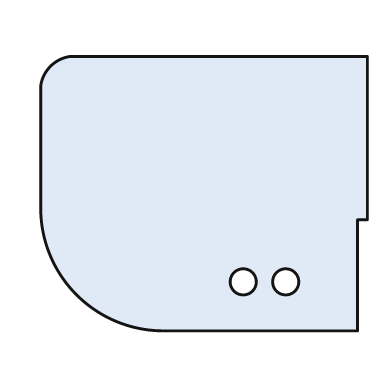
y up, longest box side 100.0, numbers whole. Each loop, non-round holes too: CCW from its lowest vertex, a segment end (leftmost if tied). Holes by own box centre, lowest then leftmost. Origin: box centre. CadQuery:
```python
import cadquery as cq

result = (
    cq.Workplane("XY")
    .moveTo(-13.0, -42.0)
    .lineTo(47.0, -42.0)
    .lineTo(47.0, -8.0)
    .lineTo(50.0, -8.0)
    .lineTo(50.0, 42.0)
    .lineTo(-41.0, 42.0)
    .threePointArc((-47.0, 39.0), (-50.0, 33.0))
    .lineTo(-50.0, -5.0)
    .threePointArc((-39.0, -31.0), (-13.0, -42.0))
    .close()
    .moveTo(12.0, -27.0)
    .circle(4.0)
    .moveTo(25.0, -27.0)
    .circle(4.0)
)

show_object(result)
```